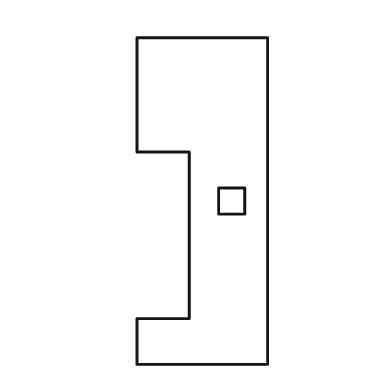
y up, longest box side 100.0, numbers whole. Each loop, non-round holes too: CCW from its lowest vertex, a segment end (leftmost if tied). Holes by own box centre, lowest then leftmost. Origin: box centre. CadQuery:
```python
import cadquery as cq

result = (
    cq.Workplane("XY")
    .moveTo(-20.0, -50.0)
    .lineTo(20.0, -50.0)
    .lineTo(20.0, 50.0)
    .lineTo(-20.0, 50.0)
    .lineTo(-20.0, 15.0)
    .lineTo(-4.0, 15.0)
    .lineTo(-4.0, -36.0)
    .lineTo(-20.0, -36.0)
    .close()
    .moveTo(5.0, -4.0)
    .lineTo(13.0, -4.0)
    .lineTo(13.0, 4.0)
    .lineTo(5.0, 4.0)
    .close()
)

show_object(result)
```